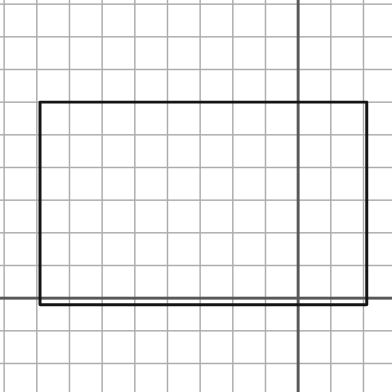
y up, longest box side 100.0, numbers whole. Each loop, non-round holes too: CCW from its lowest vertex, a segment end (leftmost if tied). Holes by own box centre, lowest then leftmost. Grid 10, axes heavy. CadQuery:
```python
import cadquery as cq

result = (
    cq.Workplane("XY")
    .moveTo(-79.0, -2.0)
    .lineTo(21.0, -2.0)
    .lineTo(21.0, 60.0)
    .lineTo(-79.0, 60.0)
    .close()
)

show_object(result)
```